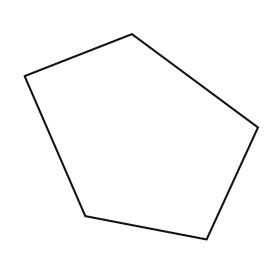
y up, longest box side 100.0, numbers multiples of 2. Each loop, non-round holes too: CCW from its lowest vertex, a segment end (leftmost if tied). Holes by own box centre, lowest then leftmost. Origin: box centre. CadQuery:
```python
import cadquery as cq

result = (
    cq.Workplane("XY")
    .moveTo(28.0, -44.0)
    .lineTo(50.0, 4.0)
    .lineTo(-4.0, 44.0)
    .lineTo(-50.0, 26.0)
    .lineTo(-24.0, -34.0)
    .close()
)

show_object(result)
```